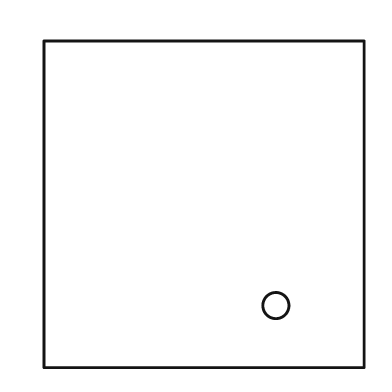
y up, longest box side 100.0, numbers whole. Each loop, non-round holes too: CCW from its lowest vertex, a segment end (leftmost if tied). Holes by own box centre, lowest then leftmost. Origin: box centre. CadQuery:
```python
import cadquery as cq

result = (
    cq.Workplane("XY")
    .moveTo(-49.0, -50.0)
    .lineTo(49.0, -50.0)
    .lineTo(49.0, 50.0)
    .lineTo(-49.0, 50.0)
    .close()
    .moveTo(22.0, -31.0)
    .circle(4.0)
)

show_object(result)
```